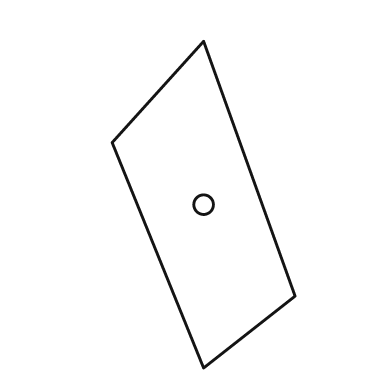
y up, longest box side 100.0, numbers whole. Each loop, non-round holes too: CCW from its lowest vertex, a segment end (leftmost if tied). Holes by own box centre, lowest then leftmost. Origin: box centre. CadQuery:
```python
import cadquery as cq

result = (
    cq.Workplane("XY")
    .moveTo(0.0, -50.0)
    .lineTo(28.0, -28.0)
    .lineTo(0.0, 50.0)
    .lineTo(-28.0, 19.0)
    .close()
    .moveTo(0.0, 0.0)
    .circle(3.0)
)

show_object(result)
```